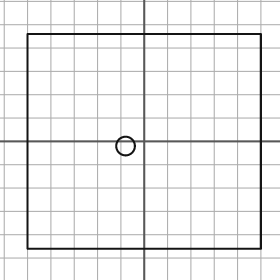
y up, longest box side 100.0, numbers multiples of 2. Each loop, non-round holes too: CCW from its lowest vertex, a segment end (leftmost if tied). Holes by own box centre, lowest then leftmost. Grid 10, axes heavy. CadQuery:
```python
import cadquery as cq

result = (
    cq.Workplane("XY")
    .moveTo(-50.0, -46.0)
    .lineTo(50.0, -46.0)
    .lineTo(50.0, 46.0)
    .lineTo(-50.0, 46.0)
    .close()
    .moveTo(-8.0, -2.0)
    .circle(4.0)
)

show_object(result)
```